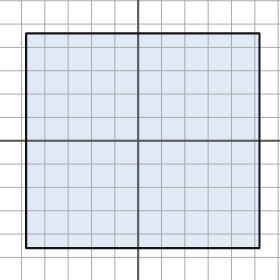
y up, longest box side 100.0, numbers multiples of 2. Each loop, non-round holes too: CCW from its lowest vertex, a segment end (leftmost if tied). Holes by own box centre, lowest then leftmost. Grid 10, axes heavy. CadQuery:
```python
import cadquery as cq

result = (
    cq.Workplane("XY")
    .moveTo(-48.0, -46.0)
    .lineTo(52.0, -46.0)
    .lineTo(52.0, 46.0)
    .lineTo(-48.0, 46.0)
    .close()
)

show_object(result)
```